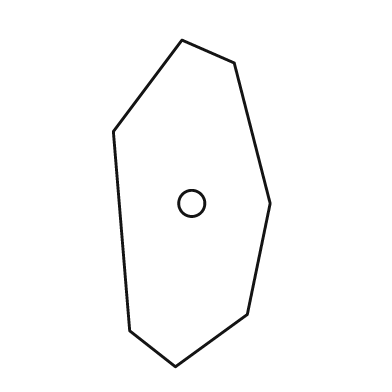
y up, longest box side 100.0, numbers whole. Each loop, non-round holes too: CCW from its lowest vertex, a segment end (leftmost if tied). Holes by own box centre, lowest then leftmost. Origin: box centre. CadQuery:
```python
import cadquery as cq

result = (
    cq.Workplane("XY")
    .moveTo(-5.0, -50.0)
    .lineTo(17.0, -34.0)
    .lineTo(24.0, 0.0)
    .lineTo(13.0, 43.0)
    .lineTo(-3.0, 50.0)
    .lineTo(-24.0, 22.0)
    .lineTo(-19.0, -39.0)
    .close()
    .moveTo(0.0, 0.0)
    .circle(4.0)
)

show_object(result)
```